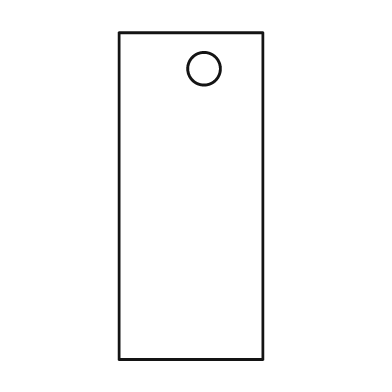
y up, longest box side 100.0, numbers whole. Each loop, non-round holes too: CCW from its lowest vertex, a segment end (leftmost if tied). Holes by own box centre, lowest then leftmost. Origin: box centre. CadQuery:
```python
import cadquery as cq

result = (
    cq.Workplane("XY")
    .moveTo(-22.0, -50.0)
    .lineTo(22.0, -50.0)
    .lineTo(22.0, 50.0)
    .lineTo(-22.0, 50.0)
    .close()
    .moveTo(4.0, 39.0)
    .circle(5.0)
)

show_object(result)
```